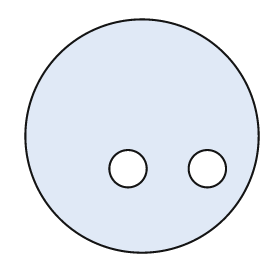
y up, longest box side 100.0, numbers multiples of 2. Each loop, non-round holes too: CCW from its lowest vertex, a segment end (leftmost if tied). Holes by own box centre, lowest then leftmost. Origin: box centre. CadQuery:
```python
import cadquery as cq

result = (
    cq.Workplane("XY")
    .moveTo(0.0, 0.0)
    .circle(50.0)
    .moveTo(-6.0, -14.0)
    .circle(8.0)
    .moveTo(28.0, -14.0)
    .circle(8.0)
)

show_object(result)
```